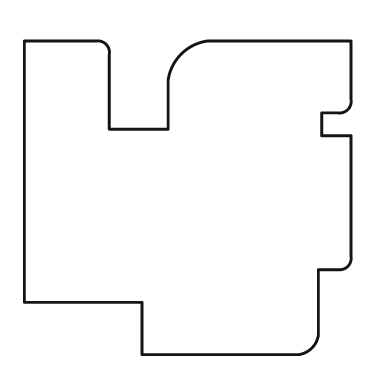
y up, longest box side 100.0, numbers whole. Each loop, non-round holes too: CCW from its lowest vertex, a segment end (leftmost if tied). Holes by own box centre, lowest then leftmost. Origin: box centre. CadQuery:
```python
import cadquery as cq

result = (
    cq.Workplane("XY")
    .moveTo(-14.0, -48.0)
    .lineTo(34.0, -48.0)
    .threePointArc((38.0, -46.0), (40.0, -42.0))
    .lineTo(40.0, -22.0)
    .lineTo(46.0, -22.0)
    .threePointArc((49.0, -21.0), (50.0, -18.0))
    .lineTo(50.0, 19.0)
    .lineTo(41.0, 19.0)
    .lineTo(41.0, 26.0)
    .lineTo(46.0, 26.0)
    .threePointArc((49.0, 27.0), (50.0, 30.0))
    .lineTo(50.0, 48.0)
    .lineTo(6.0, 48.0)
    .threePointArc((-2.0, 44.0), (-6.0, 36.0))
    .lineTo(-6.0, 21.0)
    .lineTo(-24.0, 21.0)
    .lineTo(-24.0, 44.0)
    .threePointArc((-25.0, 47.0), (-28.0, 48.0))
    .lineTo(-50.0, 48.0)
    .lineTo(-50.0, -32.0)
    .lineTo(-14.0, -32.0)
    .close()
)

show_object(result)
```